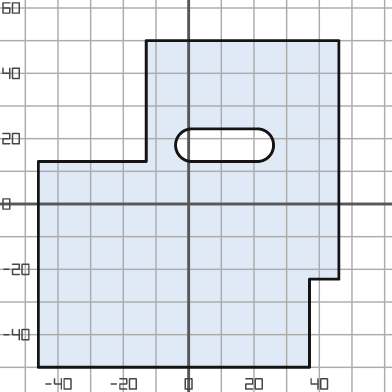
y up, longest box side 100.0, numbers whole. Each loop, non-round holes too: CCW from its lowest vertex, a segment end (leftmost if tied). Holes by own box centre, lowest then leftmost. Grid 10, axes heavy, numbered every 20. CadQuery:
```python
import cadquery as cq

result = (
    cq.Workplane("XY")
    .moveTo(-46.0, -50.0)
    .lineTo(37.0, -50.0)
    .lineTo(37.0, -23.0)
    .lineTo(46.0, -23.0)
    .lineTo(46.0, 50.0)
    .lineTo(-13.0, 50.0)
    .lineTo(-13.0, 13.0)
    .lineTo(-46.0, 13.0)
    .close()
    .moveTo(1.0, 13.0)
    .lineTo(21.0, 13.0)
    .threePointArc((26.0, 18.0), (21.0, 23.0))
    .lineTo(1.0, 23.0)
    .threePointArc((-4.0, 18.0), (1.0, 13.0))
    .close()
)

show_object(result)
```